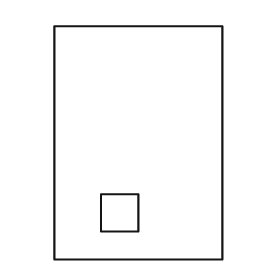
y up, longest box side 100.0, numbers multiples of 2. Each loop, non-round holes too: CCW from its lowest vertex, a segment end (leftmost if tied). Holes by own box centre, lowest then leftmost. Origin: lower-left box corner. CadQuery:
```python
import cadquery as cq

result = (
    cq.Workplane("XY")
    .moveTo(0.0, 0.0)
    .lineTo(72.0, 0.0)
    .lineTo(72.0, 100.0)
    .lineTo(0.0, 100.0)
    .close()
    .moveTo(20.0, 12.0)
    .lineTo(36.0, 12.0)
    .lineTo(36.0, 28.0)
    .lineTo(20.0, 28.0)
    .close()
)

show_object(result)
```